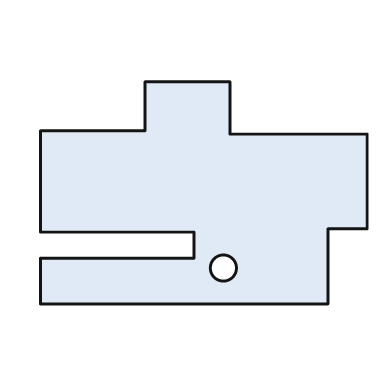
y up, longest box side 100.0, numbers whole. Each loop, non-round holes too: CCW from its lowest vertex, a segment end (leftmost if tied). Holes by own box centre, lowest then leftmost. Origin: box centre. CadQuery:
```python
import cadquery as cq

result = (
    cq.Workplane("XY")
    .moveTo(-50.0, -34.0)
    .lineTo(38.0, -34.0)
    .lineTo(38.0, -11.0)
    .lineTo(50.0, -11.0)
    .lineTo(50.0, 18.0)
    .lineTo(8.0, 18.0)
    .lineTo(8.0, 34.0)
    .lineTo(-18.0, 34.0)
    .lineTo(-18.0, 19.0)
    .lineTo(-50.0, 19.0)
    .lineTo(-50.0, -12.0)
    .lineTo(-3.0, -12.0)
    .lineTo(-3.0, -20.0)
    .lineTo(-50.0, -20.0)
    .close()
    .moveTo(6.0, -23.0)
    .circle(4.0)
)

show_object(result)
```